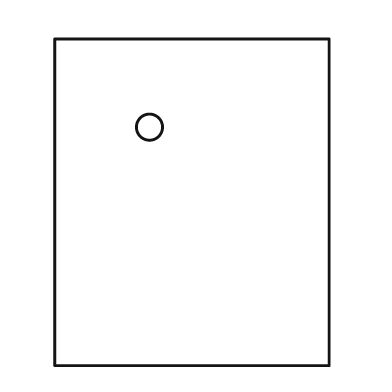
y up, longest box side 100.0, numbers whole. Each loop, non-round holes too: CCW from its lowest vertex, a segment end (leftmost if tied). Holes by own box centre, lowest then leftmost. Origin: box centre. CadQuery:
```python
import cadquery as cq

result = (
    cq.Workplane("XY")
    .moveTo(-42.0, -50.0)
    .lineTo(42.0, -50.0)
    .lineTo(42.0, 50.0)
    .lineTo(-42.0, 50.0)
    .close()
    .moveTo(-13.0, 23.0)
    .circle(4.0)
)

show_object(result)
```